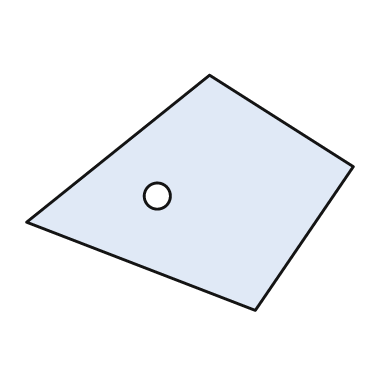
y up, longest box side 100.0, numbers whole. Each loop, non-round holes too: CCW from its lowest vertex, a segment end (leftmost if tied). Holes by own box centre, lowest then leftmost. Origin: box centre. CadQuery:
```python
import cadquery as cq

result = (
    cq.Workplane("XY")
    .moveTo(20.0, -36.0)
    .lineTo(50.0, 8.0)
    .lineTo(6.0, 36.0)
    .lineTo(-50.0, -9.0)
    .close()
    .moveTo(-10.0, -1.0)
    .circle(4.0)
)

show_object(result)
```